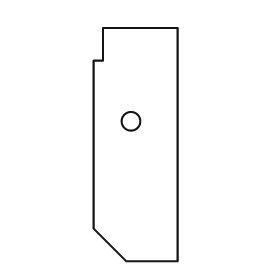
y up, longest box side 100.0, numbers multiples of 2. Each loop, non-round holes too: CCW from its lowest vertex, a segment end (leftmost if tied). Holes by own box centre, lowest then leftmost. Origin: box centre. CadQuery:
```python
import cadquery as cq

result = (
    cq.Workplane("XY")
    .moveTo(-4.0, -50.0)
    .lineTo(18.0, -50.0)
    .lineTo(18.0, 50.0)
    .lineTo(-14.0, 50.0)
    .lineTo(-14.0, 36.0)
    .lineTo(-18.0, 36.0)
    .lineTo(-18.0, -36.0)
    .close()
    .moveTo(-2.0, 10.0)
    .circle(4.0)
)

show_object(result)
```